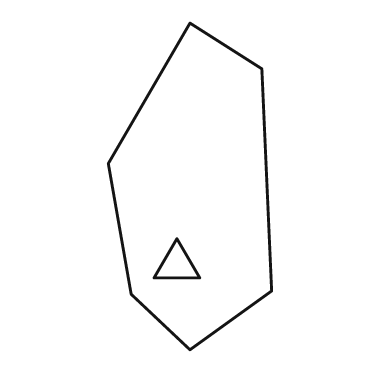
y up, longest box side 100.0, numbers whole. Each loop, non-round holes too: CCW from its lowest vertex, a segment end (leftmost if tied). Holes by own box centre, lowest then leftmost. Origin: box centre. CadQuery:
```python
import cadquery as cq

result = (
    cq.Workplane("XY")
    .moveTo(0.0, -50.0)
    .lineTo(25.0, -32.0)
    .lineTo(22.0, 36.0)
    .lineTo(0.0, 50.0)
    .lineTo(-25.0, 7.0)
    .lineTo(-18.0, -33.0)
    .close()
    .moveTo(-11.0, -28.0)
    .lineTo(3.0, -28.0)
    .lineTo(-4.0, -16.0)
    .close()
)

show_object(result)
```